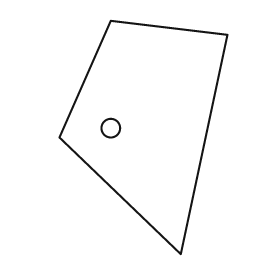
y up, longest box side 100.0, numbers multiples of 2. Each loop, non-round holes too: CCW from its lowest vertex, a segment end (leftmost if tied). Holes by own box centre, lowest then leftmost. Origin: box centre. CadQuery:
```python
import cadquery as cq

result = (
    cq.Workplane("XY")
    .moveTo(16.0, -50.0)
    .lineTo(36.0, 44.0)
    .lineTo(-14.0, 50.0)
    .lineTo(-36.0, 0.0)
    .close()
    .moveTo(-14.0, 4.0)
    .circle(4.0)
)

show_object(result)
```